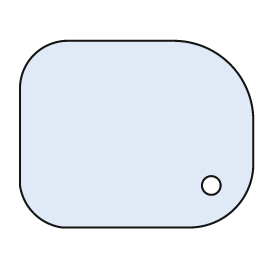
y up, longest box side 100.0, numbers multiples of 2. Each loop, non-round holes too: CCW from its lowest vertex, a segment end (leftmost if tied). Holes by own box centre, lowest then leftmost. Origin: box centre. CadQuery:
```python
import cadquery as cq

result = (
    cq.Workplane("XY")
    .moveTo(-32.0, -40.0)
    .lineTo(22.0, -40.0)
    .threePointArc((42.0, -32.0), (50.0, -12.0))
    .lineTo(50.0, 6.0)
    .threePointArc((40.0, 30.0), (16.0, 40.0))
    .lineTo(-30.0, 40.0)
    .threePointArc((-44.0, 34.0), (-50.0, 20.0))
    .lineTo(-50.0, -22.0)
    .threePointArc((-44.0, -34.0), (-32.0, -40.0))
    .close()
    .moveTo(32.0, -22.0)
    .circle(4.0)
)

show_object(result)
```